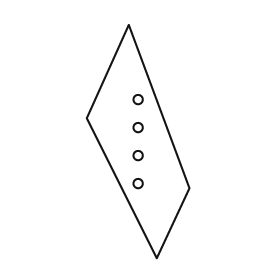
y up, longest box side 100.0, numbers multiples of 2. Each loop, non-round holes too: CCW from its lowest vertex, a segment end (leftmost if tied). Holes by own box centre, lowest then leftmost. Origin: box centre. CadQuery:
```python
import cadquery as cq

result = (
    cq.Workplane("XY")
    .moveTo(8.0, -50.0)
    .lineTo(22.0, -20.0)
    .lineTo(-4.0, 50.0)
    .lineTo(-22.0, 10.0)
    .close()
    .moveTo(0.0, -18.0)
    .circle(2.0)
    .moveTo(0.0, -6.0)
    .circle(2.0)
    .moveTo(0.0, 6.0)
    .circle(2.0)
    .moveTo(0.0, 18.0)
    .circle(2.0)
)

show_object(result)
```